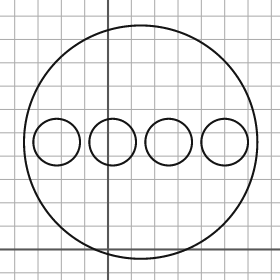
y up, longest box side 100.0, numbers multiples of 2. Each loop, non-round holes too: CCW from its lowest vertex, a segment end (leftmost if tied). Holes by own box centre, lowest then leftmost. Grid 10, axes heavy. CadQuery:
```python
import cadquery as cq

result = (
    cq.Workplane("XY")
    .moveTo(14.0, 46.0)
    .circle(50.0)
    .moveTo(-22.0, 46.0)
    .circle(10.0)
    .moveTo(2.0, 46.0)
    .circle(10.0)
    .moveTo(26.0, 46.0)
    .circle(10.0)
    .moveTo(50.0, 46.0)
    .circle(10.0)
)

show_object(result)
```